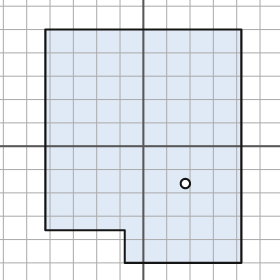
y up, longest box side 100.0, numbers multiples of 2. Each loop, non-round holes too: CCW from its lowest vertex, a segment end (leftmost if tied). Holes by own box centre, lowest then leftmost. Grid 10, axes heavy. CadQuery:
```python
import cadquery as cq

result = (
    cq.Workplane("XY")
    .moveTo(-8.0, -50.0)
    .lineTo(42.0, -50.0)
    .lineTo(42.0, 50.0)
    .lineTo(-42.0, 50.0)
    .lineTo(-42.0, -36.0)
    .lineTo(-8.0, -36.0)
    .close()
    .moveTo(18.0, -16.0)
    .circle(2.0)
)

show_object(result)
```